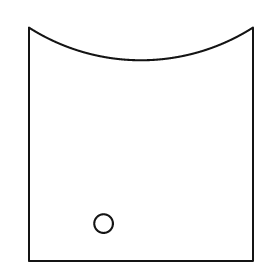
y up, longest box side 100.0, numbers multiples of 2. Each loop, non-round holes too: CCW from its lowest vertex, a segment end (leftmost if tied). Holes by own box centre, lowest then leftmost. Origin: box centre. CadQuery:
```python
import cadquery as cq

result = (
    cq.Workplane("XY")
    .moveTo(-48.0, -50.0)
    .lineTo(48.0, -50.0)
    .lineTo(48.0, 50.0)
    .threePointArc((0.0, 36.0), (-48.0, 50.0))
    .close()
    .moveTo(-16.0, -34.0)
    .circle(4.0)
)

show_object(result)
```